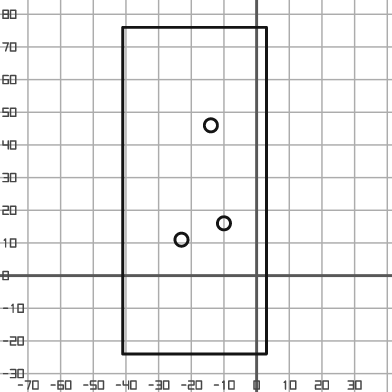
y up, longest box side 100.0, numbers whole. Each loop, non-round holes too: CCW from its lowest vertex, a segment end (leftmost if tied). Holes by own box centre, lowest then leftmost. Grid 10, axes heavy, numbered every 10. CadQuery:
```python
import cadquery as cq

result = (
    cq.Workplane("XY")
    .moveTo(-41.0, -24.0)
    .lineTo(3.0, -24.0)
    .lineTo(3.0, 76.0)
    .lineTo(-41.0, 76.0)
    .close()
    .moveTo(-23.0, 11.0)
    .circle(2.0)
    .moveTo(-10.0, 16.0)
    .circle(2.0)
    .moveTo(-14.0, 46.0)
    .circle(2.0)
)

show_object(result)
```